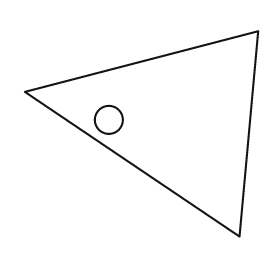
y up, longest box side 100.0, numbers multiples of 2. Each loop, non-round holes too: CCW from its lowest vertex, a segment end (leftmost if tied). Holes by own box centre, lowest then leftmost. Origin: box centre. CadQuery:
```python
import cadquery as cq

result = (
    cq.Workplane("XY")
    .moveTo(42.0, -44.0)
    .lineTo(50.0, 44.0)
    .lineTo(-50.0, 18.0)
    .close()
    .moveTo(-14.0, 6.0)
    .circle(6.0)
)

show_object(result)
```